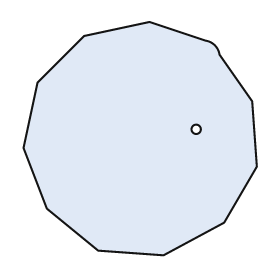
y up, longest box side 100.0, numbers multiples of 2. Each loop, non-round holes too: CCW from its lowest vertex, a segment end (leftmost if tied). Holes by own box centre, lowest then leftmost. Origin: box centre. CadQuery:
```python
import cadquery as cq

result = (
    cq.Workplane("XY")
    .moveTo(10.0, -50.0)
    .lineTo(36.0, -36.0)
    .lineTo(50.0, -12.0)
    .lineTo(48.0, 16.0)
    .lineTo(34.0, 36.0)
    .threePointArc((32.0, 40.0), (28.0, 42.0))
    .lineTo(4.0, 50.0)
    .lineTo(-24.0, 44.0)
    .lineTo(-44.0, 24.0)
    .lineTo(-50.0, -4.0)
    .lineTo(-40.0, -30.0)
    .lineTo(-18.0, -48.0)
    .close()
    .moveTo(24.0, 4.0)
    .circle(2.0)
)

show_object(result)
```